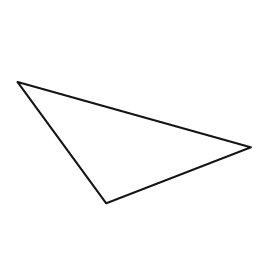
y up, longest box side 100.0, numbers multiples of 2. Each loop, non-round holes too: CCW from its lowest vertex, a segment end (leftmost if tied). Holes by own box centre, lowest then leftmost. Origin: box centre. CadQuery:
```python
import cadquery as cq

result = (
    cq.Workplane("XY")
    .moveTo(-12.0, -26.0)
    .lineTo(50.0, -2.0)
    .lineTo(-50.0, 26.0)
    .close()
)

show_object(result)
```